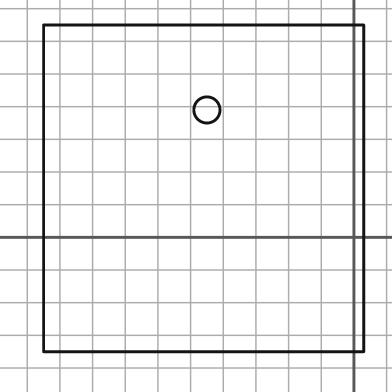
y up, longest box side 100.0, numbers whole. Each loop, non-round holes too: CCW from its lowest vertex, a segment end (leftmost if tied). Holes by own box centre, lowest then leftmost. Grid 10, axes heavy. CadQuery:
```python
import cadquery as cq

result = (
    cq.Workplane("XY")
    .moveTo(-95.0, -35.0)
    .lineTo(3.0, -35.0)
    .lineTo(3.0, 65.0)
    .lineTo(-95.0, 65.0)
    .close()
    .moveTo(-45.0, 39.0)
    .circle(4.0)
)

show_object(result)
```